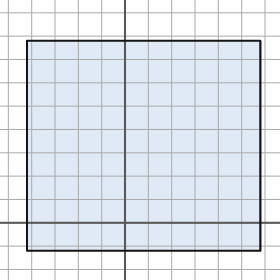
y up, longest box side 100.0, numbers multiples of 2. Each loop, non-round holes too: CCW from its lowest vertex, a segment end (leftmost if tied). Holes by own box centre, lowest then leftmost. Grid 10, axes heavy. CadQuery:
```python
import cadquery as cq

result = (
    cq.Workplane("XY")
    .moveTo(-42.0, -12.0)
    .lineTo(58.0, -12.0)
    .lineTo(58.0, 78.0)
    .lineTo(-42.0, 78.0)
    .close()
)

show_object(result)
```